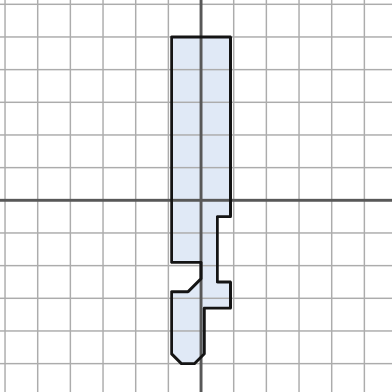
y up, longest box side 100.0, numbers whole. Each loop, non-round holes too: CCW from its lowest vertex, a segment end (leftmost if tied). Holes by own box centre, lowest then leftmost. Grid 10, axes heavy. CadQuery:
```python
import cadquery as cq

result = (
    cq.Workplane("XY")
    .moveTo(-6.0, -50.0)
    .lineTo(-2.0, -50.0)
    .lineTo(1.0, -47.0)
    .lineTo(1.0, -33.0)
    .lineTo(9.0, -33.0)
    .lineTo(9.0, -25.0)
    .lineTo(5.0, -25.0)
    .lineTo(5.0, -5.0)
    .lineTo(9.0, -5.0)
    .lineTo(9.0, 50.0)
    .lineTo(-9.0, 50.0)
    .lineTo(-9.0, -19.0)
    .lineTo(0.0, -19.0)
    .lineTo(0.0, -24.0)
    .lineTo(-4.0, -28.0)
    .lineTo(-9.0, -28.0)
    .lineTo(-9.0, -47.0)
    .close()
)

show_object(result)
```